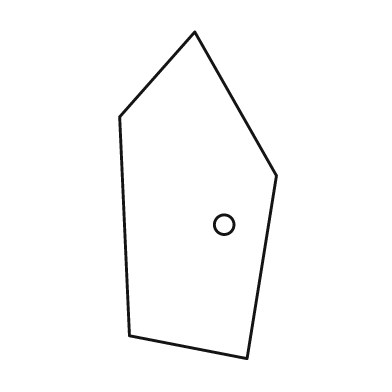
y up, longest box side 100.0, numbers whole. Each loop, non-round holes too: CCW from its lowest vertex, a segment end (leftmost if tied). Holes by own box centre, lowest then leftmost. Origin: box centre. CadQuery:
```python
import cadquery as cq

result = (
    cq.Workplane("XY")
    .moveTo(15.0, -50.0)
    .lineTo(24.0, 6.0)
    .lineTo(-1.0, 50.0)
    .lineTo(-24.0, 24.0)
    .lineTo(-21.0, -43.0)
    .close()
    .moveTo(8.0, -9.0)
    .circle(3.0)
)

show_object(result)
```